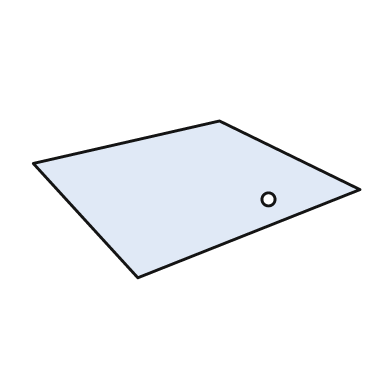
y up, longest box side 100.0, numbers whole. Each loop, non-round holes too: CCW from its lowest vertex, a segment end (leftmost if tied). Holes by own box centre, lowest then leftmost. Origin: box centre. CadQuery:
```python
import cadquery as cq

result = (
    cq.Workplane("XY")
    .moveTo(-18.0, -24.0)
    .lineTo(50.0, 3.0)
    .lineTo(7.0, 24.0)
    .lineTo(-50.0, 11.0)
    .close()
    .moveTo(22.0, 0.0)
    .circle(2.0)
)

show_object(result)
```